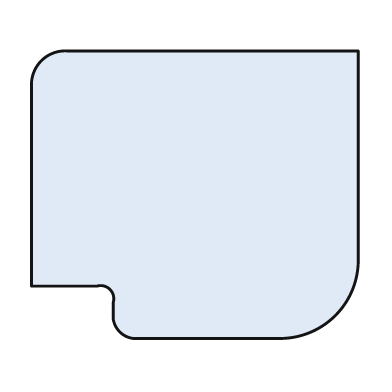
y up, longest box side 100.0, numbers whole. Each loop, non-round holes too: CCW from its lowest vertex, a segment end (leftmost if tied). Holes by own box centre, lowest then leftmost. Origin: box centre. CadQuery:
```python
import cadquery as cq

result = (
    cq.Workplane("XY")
    .moveTo(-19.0, -44.0)
    .lineTo(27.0, -44.0)
    .threePointArc((43.0, -37.0), (50.0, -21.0))
    .lineTo(50.0, 44.0)
    .lineTo(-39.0, 44.0)
    .threePointArc((-47.0, 41.0), (-50.0, 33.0))
    .lineTo(-50.0, -28.0)
    .lineTo(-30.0, -28.0)
    .threePointArc((-26.0, -29.0), (-25.0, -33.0))
    .lineTo(-25.0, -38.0)
    .threePointArc((-23.0, -42.0), (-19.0, -44.0))
    .close()
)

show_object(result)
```